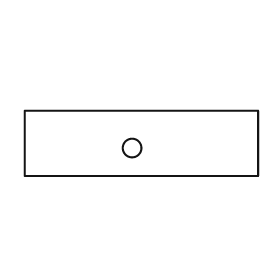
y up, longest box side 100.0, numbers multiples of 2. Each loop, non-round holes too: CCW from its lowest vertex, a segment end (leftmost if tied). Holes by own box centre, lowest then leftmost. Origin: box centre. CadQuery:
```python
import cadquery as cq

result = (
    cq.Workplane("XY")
    .moveTo(-50.0, -14.0)
    .lineTo(50.0, -14.0)
    .lineTo(50.0, 14.0)
    .lineTo(-50.0, 14.0)
    .close()
    .moveTo(-4.0, -2.0)
    .circle(4.0)
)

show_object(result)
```